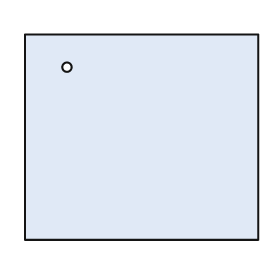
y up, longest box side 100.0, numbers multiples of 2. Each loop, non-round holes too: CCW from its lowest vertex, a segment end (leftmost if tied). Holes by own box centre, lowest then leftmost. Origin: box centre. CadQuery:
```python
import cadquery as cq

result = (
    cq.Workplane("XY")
    .moveTo(-50.0, -44.0)
    .lineTo(50.0, -44.0)
    .lineTo(50.0, 44.0)
    .lineTo(-50.0, 44.0)
    .close()
    .moveTo(-32.0, 30.0)
    .circle(2.0)
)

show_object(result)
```